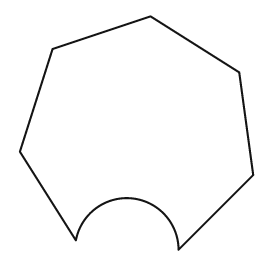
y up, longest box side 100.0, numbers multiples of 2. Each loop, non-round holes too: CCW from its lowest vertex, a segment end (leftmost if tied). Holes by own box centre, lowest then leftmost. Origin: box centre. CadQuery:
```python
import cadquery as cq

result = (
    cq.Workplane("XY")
    .moveTo(18.0, -50.0)
    .lineTo(50.0, -18.0)
    .lineTo(44.0, 26.0)
    .lineTo(6.0, 50.0)
    .lineTo(-36.0, 36.0)
    .lineTo(-50.0, -8.0)
    .lineTo(-26.0, -46.0)
    .threePointArc((-2.0, -28.0), (18.0, -50.0))
    .close()
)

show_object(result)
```